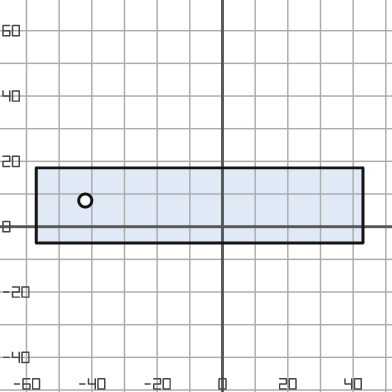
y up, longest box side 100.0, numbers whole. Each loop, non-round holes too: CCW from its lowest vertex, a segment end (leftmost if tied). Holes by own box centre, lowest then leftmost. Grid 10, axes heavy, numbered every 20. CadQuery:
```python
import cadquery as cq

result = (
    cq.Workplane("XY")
    .moveTo(-57.0, -5.0)
    .lineTo(43.0, -5.0)
    .lineTo(43.0, 18.0)
    .lineTo(-57.0, 18.0)
    .close()
    .moveTo(-42.0, 8.0)
    .circle(2.0)
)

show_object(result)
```